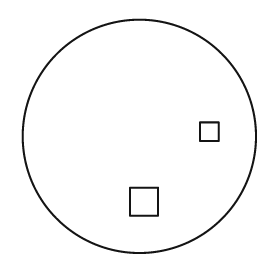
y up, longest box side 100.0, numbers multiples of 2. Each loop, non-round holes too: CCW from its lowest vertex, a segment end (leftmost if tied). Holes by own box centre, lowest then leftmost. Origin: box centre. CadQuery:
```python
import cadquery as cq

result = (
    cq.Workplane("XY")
    .moveTo(0.0, 0.0)
    .circle(50.0)
    .moveTo(-4.0, -34.0)
    .lineTo(8.0, -34.0)
    .lineTo(8.0, -22.0)
    .lineTo(-4.0, -22.0)
    .close()
    .moveTo(26.0, -2.0)
    .lineTo(34.0, -2.0)
    .lineTo(34.0, 6.0)
    .lineTo(26.0, 6.0)
    .close()
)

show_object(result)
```